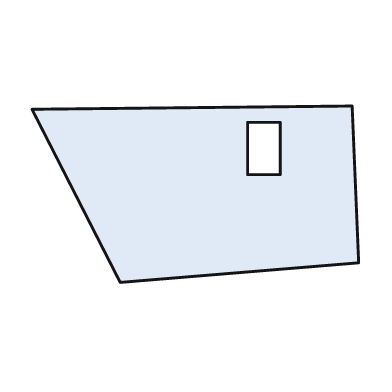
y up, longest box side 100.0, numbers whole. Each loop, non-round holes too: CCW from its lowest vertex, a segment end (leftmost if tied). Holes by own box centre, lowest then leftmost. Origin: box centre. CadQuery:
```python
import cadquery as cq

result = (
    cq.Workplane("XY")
    .moveTo(-23.0, -27.0)
    .lineTo(50.0, -21.0)
    .lineTo(48.0, 27.0)
    .lineTo(-50.0, 26.0)
    .close()
    .moveTo(16.0, 6.0)
    .lineTo(26.0, 6.0)
    .lineTo(26.0, 22.0)
    .lineTo(16.0, 22.0)
    .close()
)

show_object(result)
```